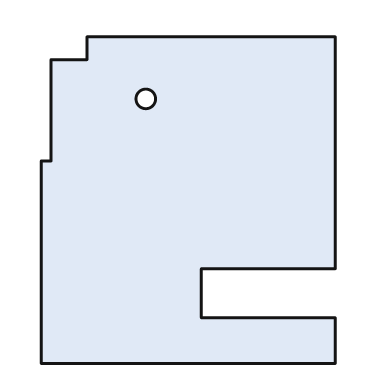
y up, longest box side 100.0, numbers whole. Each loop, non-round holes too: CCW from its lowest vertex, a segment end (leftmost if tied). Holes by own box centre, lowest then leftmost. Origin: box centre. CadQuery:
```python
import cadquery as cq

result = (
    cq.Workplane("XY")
    .moveTo(-45.0, -50.0)
    .lineTo(45.0, -50.0)
    .lineTo(45.0, -36.0)
    .lineTo(4.0, -36.0)
    .lineTo(4.0, -21.0)
    .lineTo(45.0, -21.0)
    .lineTo(45.0, 50.0)
    .lineTo(-31.0, 50.0)
    .lineTo(-31.0, 43.0)
    .lineTo(-42.0, 43.0)
    .lineTo(-42.0, 12.0)
    .lineTo(-45.0, 12.0)
    .close()
    .moveTo(-13.0, 31.0)
    .circle(3.0)
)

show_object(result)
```